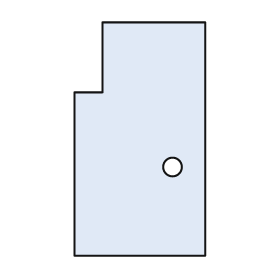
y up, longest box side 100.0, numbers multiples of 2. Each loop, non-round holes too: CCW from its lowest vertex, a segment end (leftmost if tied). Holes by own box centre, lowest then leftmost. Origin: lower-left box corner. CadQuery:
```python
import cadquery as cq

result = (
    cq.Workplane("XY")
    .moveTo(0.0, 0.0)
    .lineTo(56.0, 0.0)
    .lineTo(56.0, 100.0)
    .lineTo(12.0, 100.0)
    .lineTo(12.0, 70.0)
    .lineTo(0.0, 70.0)
    .close()
    .moveTo(42.0, 38.0)
    .circle(4.0)
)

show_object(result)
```